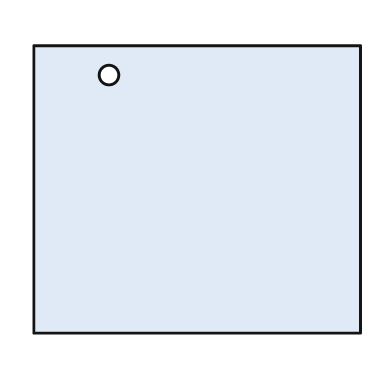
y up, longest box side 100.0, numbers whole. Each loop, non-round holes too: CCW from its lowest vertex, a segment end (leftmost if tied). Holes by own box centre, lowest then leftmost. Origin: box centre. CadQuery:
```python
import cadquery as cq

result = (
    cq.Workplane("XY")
    .moveTo(-50.0, -44.0)
    .lineTo(50.0, -44.0)
    .lineTo(50.0, 44.0)
    .lineTo(-50.0, 44.0)
    .close()
    .moveTo(-27.0, 35.0)
    .circle(3.0)
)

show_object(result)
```